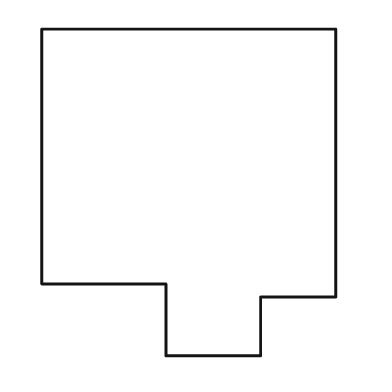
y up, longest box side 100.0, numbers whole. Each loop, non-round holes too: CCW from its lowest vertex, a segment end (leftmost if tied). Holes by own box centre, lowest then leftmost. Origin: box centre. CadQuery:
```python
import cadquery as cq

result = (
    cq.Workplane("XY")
    .moveTo(-7.0, -50.0)
    .lineTo(22.0, -50.0)
    .lineTo(22.0, -32.0)
    .lineTo(45.0, -32.0)
    .lineTo(45.0, 50.0)
    .lineTo(-45.0, 50.0)
    .lineTo(-45.0, -28.0)
    .lineTo(-7.0, -28.0)
    .close()
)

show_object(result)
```